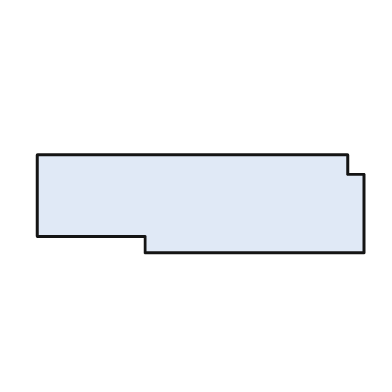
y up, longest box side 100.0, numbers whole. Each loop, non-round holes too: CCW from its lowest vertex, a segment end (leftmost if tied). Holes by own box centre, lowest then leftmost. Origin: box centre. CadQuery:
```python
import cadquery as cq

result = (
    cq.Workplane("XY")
    .moveTo(-17.0, -15.0)
    .lineTo(50.0, -15.0)
    .lineTo(50.0, 9.0)
    .lineTo(45.0, 9.0)
    .lineTo(45.0, 15.0)
    .lineTo(-50.0, 15.0)
    .lineTo(-50.0, -10.0)
    .lineTo(-17.0, -10.0)
    .close()
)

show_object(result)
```